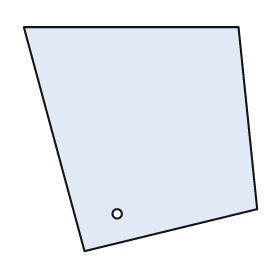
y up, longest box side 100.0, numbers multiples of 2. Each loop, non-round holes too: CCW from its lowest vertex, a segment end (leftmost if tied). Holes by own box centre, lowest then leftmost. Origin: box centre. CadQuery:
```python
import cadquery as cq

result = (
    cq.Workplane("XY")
    .moveTo(-24.0, -48.0)
    .lineTo(50.0, -30.0)
    .lineTo(42.0, 48.0)
    .lineTo(-50.0, 48.0)
    .close()
    .moveTo(-10.0, -32.0)
    .circle(2.0)
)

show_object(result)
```